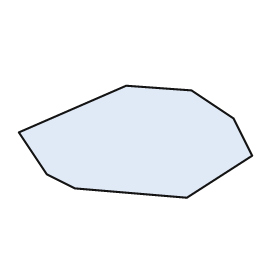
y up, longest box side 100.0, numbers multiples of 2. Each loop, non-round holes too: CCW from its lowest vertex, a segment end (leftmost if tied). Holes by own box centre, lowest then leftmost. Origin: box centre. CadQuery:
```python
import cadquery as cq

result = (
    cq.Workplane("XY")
    .moveTo(22.0, -24.0)
    .lineTo(50.0, -6.0)
    .lineTo(42.0, 10.0)
    .lineTo(24.0, 22.0)
    .lineTo(-4.0, 24.0)
    .lineTo(-50.0, 4.0)
    .lineTo(-38.0, -14.0)
    .lineTo(-26.0, -20.0)
    .close()
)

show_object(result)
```